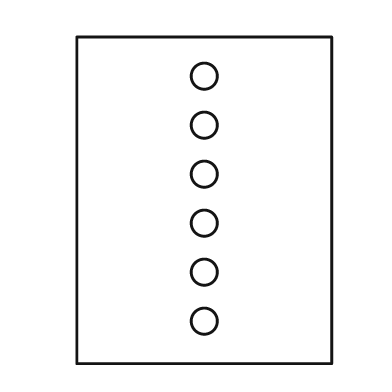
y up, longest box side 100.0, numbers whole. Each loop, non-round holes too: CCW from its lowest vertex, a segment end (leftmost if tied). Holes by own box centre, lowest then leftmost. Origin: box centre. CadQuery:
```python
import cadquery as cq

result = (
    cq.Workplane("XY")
    .moveTo(-39.0, -50.0)
    .lineTo(39.0, -50.0)
    .lineTo(39.0, 50.0)
    .lineTo(-39.0, 50.0)
    .close()
    .moveTo(0.0, -37.0)
    .circle(4.0)
    .moveTo(0.0, -22.0)
    .circle(4.0)
    .moveTo(0.0, -7.0)
    .circle(4.0)
    .moveTo(0.0, 8.0)
    .circle(4.0)
    .moveTo(0.0, 23.0)
    .circle(4.0)
    .moveTo(0.0, 38.0)
    .circle(4.0)
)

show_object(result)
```